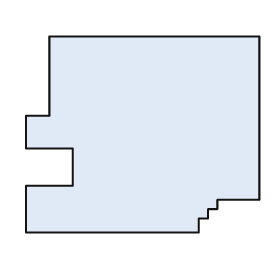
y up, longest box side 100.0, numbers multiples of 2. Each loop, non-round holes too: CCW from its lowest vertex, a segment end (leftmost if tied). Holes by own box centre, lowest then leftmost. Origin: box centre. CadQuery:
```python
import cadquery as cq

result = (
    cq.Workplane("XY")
    .moveTo(-50.0, -42.0)
    .lineTo(24.0, -42.0)
    .lineTo(24.0, -36.0)
    .lineTo(28.0, -36.0)
    .lineTo(28.0, -32.0)
    .lineTo(32.0, -32.0)
    .lineTo(32.0, -28.0)
    .lineTo(50.0, -28.0)
    .lineTo(50.0, 42.0)
    .lineTo(-40.0, 42.0)
    .lineTo(-40.0, 8.0)
    .lineTo(-50.0, 8.0)
    .lineTo(-50.0, -6.0)
    .lineTo(-30.0, -6.0)
    .lineTo(-30.0, -22.0)
    .lineTo(-50.0, -22.0)
    .close()
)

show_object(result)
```